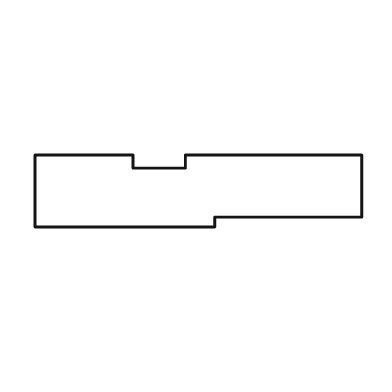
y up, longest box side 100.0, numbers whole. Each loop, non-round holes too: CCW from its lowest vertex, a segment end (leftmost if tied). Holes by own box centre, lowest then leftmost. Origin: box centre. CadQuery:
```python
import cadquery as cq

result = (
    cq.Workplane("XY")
    .moveTo(-50.0, -11.0)
    .lineTo(5.0, -11.0)
    .lineTo(5.0, -8.0)
    .lineTo(50.0, -8.0)
    .lineTo(50.0, 11.0)
    .lineTo(-4.0, 11.0)
    .lineTo(-4.0, 7.0)
    .lineTo(-20.0, 7.0)
    .lineTo(-20.0, 11.0)
    .lineTo(-50.0, 11.0)
    .close()
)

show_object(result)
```